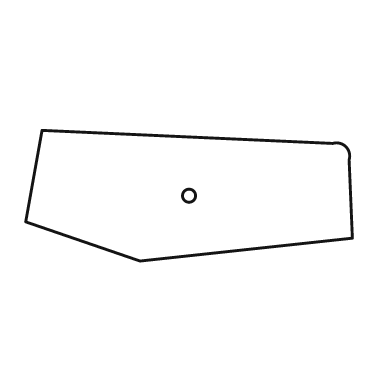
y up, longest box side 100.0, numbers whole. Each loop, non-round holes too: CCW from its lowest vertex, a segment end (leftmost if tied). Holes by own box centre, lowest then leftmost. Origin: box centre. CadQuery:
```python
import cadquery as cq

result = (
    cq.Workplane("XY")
    .moveTo(-15.0, -20.0)
    .lineTo(50.0, -13.0)
    .lineTo(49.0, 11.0)
    .threePointArc((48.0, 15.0), (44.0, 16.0))
    .lineTo(-45.0, 20.0)
    .lineTo(-50.0, -8.0)
    .close()
    .moveTo(0.0, 0.0)
    .circle(2.0)
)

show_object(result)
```